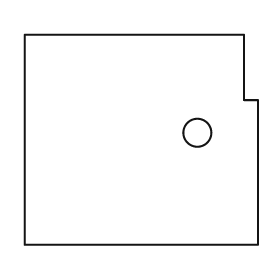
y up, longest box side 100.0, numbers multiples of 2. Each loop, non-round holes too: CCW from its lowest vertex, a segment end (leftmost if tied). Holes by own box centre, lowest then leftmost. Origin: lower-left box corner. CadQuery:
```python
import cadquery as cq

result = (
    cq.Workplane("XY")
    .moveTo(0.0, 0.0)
    .lineTo(100.0, 0.0)
    .lineTo(100.0, 62.0)
    .lineTo(94.0, 62.0)
    .lineTo(94.0, 90.0)
    .lineTo(0.0, 90.0)
    .close()
    .moveTo(74.0, 48.0)
    .circle(6.0)
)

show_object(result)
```